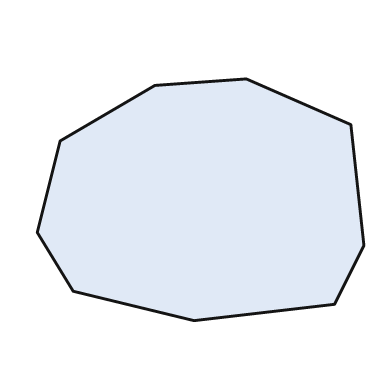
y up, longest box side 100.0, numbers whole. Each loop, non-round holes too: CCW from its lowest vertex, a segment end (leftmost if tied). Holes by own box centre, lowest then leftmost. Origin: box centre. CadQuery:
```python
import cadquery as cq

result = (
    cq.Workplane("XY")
    .moveTo(-2.0, -37.0)
    .lineTo(41.0, -32.0)
    .lineTo(50.0, -14.0)
    .lineTo(46.0, 23.0)
    .lineTo(14.0, 37.0)
    .lineTo(-14.0, 35.0)
    .lineTo(-43.0, 18.0)
    .lineTo(-50.0, -10.0)
    .lineTo(-39.0, -28.0)
    .close()
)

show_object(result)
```